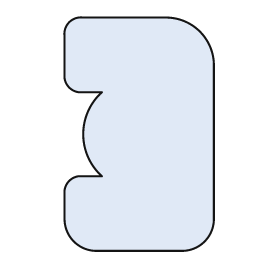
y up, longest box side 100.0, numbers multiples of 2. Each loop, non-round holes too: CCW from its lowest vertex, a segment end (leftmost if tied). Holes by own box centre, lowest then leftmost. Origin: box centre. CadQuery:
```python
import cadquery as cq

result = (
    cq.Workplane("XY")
    .moveTo(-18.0, -50.0)
    .lineTo(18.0, -50.0)
    .threePointArc((28.0, -46.0), (32.0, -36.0))
    .lineTo(32.0, 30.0)
    .threePointArc((26.0, 44.0), (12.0, 50.0))
    .lineTo(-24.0, 50.0)
    .threePointArc((-30.0, 48.0), (-32.0, 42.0))
    .lineTo(-32.0, 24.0)
    .threePointArc((-30.0, 20.0), (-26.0, 18.0))
    .lineTo(-16.0, 18.0)
    .threePointArc((-24.0, 0.0), (-16.0, -18.0))
    .lineTo(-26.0, -18.0)
    .threePointArc((-30.0, -20.0), (-32.0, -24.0))
    .lineTo(-32.0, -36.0)
    .threePointArc((-28.0, -46.0), (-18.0, -50.0))
    .close()
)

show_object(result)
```